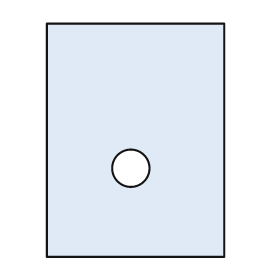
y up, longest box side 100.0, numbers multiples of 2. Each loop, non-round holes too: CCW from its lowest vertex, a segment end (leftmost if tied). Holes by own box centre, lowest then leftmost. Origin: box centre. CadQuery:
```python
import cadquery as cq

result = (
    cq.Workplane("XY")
    .moveTo(-38.0, -50.0)
    .lineTo(38.0, -50.0)
    .lineTo(38.0, 50.0)
    .lineTo(-38.0, 50.0)
    .close()
    .moveTo(-2.0, -12.0)
    .circle(8.0)
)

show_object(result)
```